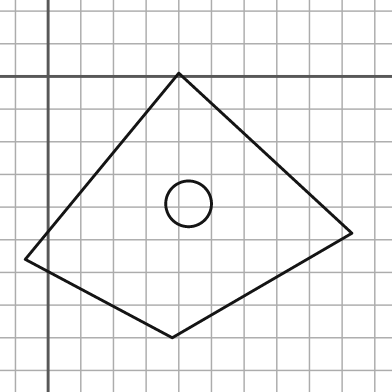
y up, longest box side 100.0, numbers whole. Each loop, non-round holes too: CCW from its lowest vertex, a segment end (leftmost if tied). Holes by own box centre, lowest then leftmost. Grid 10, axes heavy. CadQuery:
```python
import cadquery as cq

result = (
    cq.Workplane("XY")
    .moveTo(38.0, -80.0)
    .lineTo(93.0, -48.0)
    .lineTo(40.0, 1.0)
    .lineTo(-7.0, -56.0)
    .close()
    .moveTo(43.0, -39.0)
    .circle(7.0)
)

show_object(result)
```